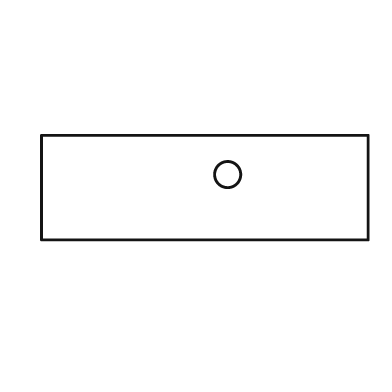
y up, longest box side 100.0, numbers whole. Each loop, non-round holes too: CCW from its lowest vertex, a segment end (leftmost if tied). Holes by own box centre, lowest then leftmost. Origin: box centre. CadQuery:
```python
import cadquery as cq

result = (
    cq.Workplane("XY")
    .moveTo(-50.0, -16.0)
    .lineTo(50.0, -16.0)
    .lineTo(50.0, 16.0)
    .lineTo(-50.0, 16.0)
    .close()
    .moveTo(7.0, 4.0)
    .circle(4.0)
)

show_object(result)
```